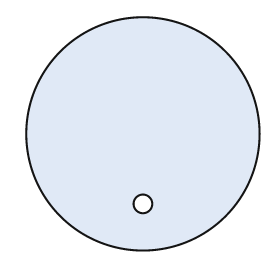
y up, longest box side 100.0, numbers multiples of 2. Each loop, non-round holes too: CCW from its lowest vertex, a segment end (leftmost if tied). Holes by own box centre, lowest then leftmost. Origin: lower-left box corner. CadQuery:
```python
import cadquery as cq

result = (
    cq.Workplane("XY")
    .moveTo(50.0, 50.0)
    .circle(50.0)
    .moveTo(50.0, 20.0)
    .circle(4.0)
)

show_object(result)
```